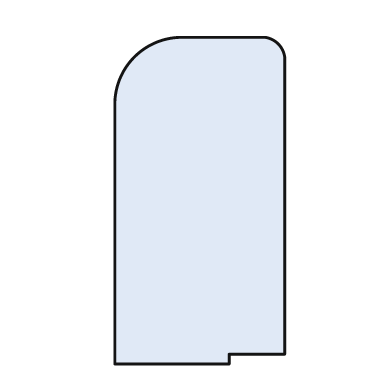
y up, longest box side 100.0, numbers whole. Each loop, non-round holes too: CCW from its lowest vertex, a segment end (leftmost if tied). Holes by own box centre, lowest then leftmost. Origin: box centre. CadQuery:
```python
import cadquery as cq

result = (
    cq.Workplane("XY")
    .moveTo(-26.0, -50.0)
    .lineTo(9.0, -50.0)
    .lineTo(9.0, -47.0)
    .lineTo(26.0, -47.0)
    .lineTo(26.0, 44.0)
    .threePointArc((24.0, 48.0), (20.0, 50.0))
    .lineTo(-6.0, 50.0)
    .threePointArc((-20.0, 44.0), (-26.0, 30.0))
    .close()
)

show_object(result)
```